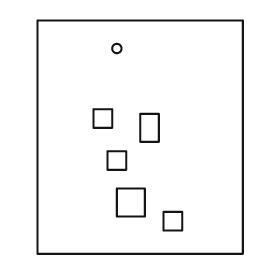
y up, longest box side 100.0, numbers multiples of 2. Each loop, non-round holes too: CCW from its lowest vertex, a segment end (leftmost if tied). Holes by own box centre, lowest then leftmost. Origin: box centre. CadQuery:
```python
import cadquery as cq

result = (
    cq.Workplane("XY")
    .moveTo(-44.0, -50.0)
    .lineTo(44.0, -50.0)
    .lineTo(44.0, 50.0)
    .lineTo(-44.0, 50.0)
    .close()
    .moveTo(10.0, -40.0)
    .lineTo(18.0, -40.0)
    .lineTo(18.0, -32.0)
    .lineTo(10.0, -32.0)
    .close()
    .moveTo(-10.0, -34.0)
    .lineTo(2.0, -34.0)
    .lineTo(2.0, -22.0)
    .lineTo(-10.0, -22.0)
    .close()
    .moveTo(-14.0, -14.0)
    .lineTo(-6.0, -14.0)
    .lineTo(-6.0, -6.0)
    .lineTo(-14.0, -6.0)
    .close()
    .moveTo(0.0, -2.0)
    .lineTo(8.0, -2.0)
    .lineTo(8.0, 10.0)
    .lineTo(0.0, 10.0)
    .close()
    .moveTo(-20.0, 4.0)
    .lineTo(-12.0, 4.0)
    .lineTo(-12.0, 12.0)
    .lineTo(-20.0, 12.0)
    .close()
    .moveTo(-10.0, 38.0)
    .circle(2.0)
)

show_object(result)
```